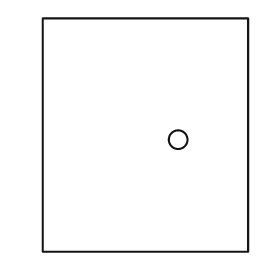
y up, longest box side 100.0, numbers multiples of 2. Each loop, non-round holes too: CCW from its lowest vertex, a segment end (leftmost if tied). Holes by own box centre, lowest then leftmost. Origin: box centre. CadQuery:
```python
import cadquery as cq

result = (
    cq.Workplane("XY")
    .moveTo(-44.0, -50.0)
    .lineTo(44.0, -50.0)
    .lineTo(44.0, 50.0)
    .lineTo(-44.0, 50.0)
    .close()
    .moveTo(14.0, -2.0)
    .circle(4.0)
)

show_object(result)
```